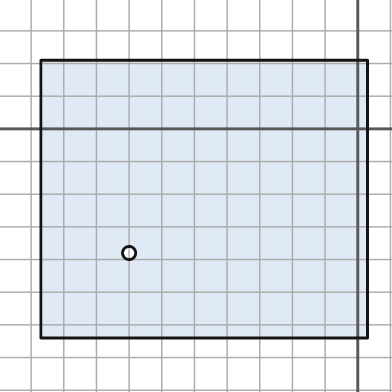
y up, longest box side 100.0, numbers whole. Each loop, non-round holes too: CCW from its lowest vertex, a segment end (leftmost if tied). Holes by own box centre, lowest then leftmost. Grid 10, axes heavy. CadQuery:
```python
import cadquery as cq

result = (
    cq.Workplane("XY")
    .moveTo(-97.0, -64.0)
    .lineTo(3.0, -64.0)
    .lineTo(3.0, 21.0)
    .lineTo(-97.0, 21.0)
    .close()
    .moveTo(-70.0, -38.0)
    .circle(2.0)
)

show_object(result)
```